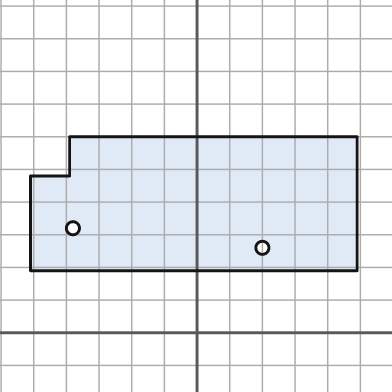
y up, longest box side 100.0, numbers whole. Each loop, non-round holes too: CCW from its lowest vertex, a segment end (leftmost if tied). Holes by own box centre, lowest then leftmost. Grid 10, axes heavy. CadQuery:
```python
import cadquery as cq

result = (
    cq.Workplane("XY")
    .moveTo(-51.0, 19.0)
    .lineTo(49.0, 19.0)
    .lineTo(49.0, 60.0)
    .lineTo(-39.0, 60.0)
    .lineTo(-39.0, 48.0)
    .lineTo(-51.0, 48.0)
    .close()
    .moveTo(20.0, 26.0)
    .circle(2.0)
    .moveTo(-38.0, 32.0)
    .circle(2.0)
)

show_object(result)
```